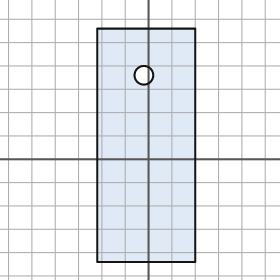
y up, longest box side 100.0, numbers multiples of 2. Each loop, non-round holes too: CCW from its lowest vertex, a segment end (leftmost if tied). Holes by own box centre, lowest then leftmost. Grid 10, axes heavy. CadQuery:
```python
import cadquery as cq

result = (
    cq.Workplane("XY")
    .moveTo(-22.0, -44.0)
    .lineTo(20.0, -44.0)
    .lineTo(20.0, 56.0)
    .lineTo(-22.0, 56.0)
    .close()
    .moveTo(-2.0, 36.0)
    .circle(4.0)
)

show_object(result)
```